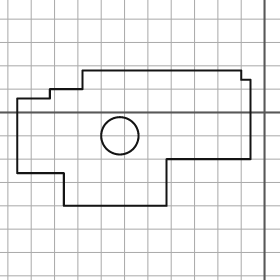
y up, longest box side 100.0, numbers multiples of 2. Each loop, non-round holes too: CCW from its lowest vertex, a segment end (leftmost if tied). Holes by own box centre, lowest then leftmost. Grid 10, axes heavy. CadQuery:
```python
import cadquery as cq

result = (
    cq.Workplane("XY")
    .moveTo(-86.0, -40.0)
    .lineTo(-42.0, -40.0)
    .lineTo(-42.0, -20.0)
    .lineTo(-6.0, -20.0)
    .lineTo(-6.0, 14.0)
    .lineTo(-10.0, 14.0)
    .lineTo(-10.0, 18.0)
    .lineTo(-78.0, 18.0)
    .lineTo(-78.0, 10.0)
    .lineTo(-92.0, 10.0)
    .lineTo(-92.0, 6.0)
    .lineTo(-106.0, 6.0)
    .lineTo(-106.0, -26.0)
    .lineTo(-86.0, -26.0)
    .close()
    .moveTo(-62.0, -10.0)
    .circle(8.0)
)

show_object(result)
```